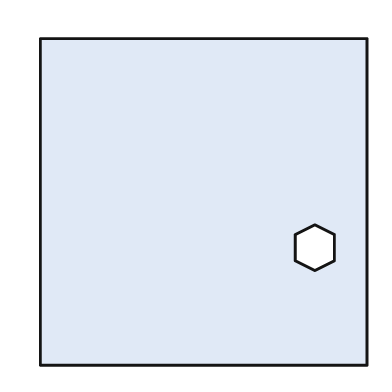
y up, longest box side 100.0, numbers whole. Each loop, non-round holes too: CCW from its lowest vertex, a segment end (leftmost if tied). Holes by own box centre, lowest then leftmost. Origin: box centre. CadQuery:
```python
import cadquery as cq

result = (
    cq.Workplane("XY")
    .moveTo(-50.0, -50.0)
    .lineTo(50.0, -50.0)
    .lineTo(50.0, 50.0)
    .lineTo(-50.0, 50.0)
    .close()
    .moveTo(34.0, -21.0)
    .lineTo(40.0, -18.0)
    .lineTo(40.0, -10.0)
    .lineTo(34.0, -7.0)
    .lineTo(28.0, -10.0)
    .lineTo(28.0, -18.0)
    .close()
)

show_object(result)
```